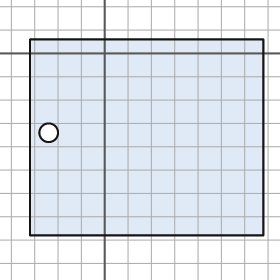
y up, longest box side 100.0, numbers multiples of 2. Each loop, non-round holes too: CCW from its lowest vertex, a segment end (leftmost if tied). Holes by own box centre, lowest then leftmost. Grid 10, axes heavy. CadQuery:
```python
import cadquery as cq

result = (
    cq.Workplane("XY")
    .moveTo(-32.0, -78.0)
    .lineTo(68.0, -78.0)
    .lineTo(68.0, 6.0)
    .lineTo(-32.0, 6.0)
    .close()
    .moveTo(-24.0, -34.0)
    .circle(4.0)
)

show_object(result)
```